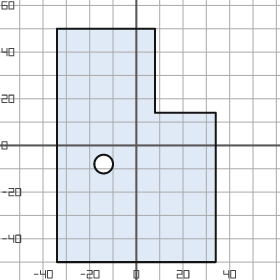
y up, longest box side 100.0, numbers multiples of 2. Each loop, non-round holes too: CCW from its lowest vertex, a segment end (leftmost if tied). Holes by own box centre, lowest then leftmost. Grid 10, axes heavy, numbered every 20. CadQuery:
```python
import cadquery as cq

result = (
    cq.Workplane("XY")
    .moveTo(-34.0, -50.0)
    .lineTo(34.0, -50.0)
    .lineTo(34.0, 14.0)
    .lineTo(8.0, 14.0)
    .lineTo(8.0, 50.0)
    .lineTo(-34.0, 50.0)
    .close()
    .moveTo(-14.0, -8.0)
    .circle(4.0)
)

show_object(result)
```